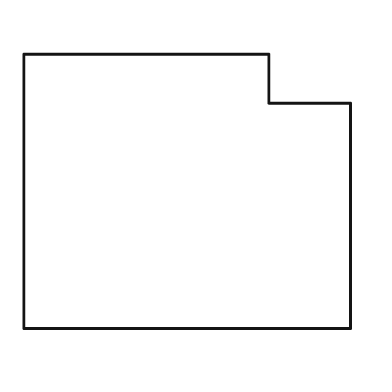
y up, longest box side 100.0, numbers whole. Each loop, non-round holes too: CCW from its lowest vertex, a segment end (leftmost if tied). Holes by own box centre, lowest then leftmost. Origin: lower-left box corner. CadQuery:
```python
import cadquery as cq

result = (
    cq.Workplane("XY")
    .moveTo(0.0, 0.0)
    .lineTo(100.0, 0.0)
    .lineTo(100.0, 69.0)
    .lineTo(75.0, 69.0)
    .lineTo(75.0, 84.0)
    .lineTo(0.0, 84.0)
    .close()
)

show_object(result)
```